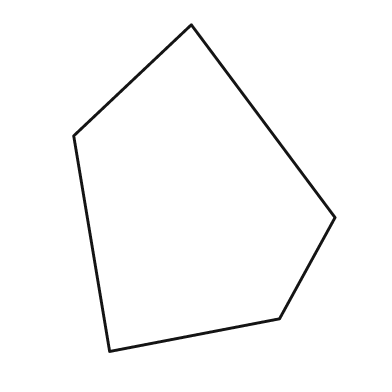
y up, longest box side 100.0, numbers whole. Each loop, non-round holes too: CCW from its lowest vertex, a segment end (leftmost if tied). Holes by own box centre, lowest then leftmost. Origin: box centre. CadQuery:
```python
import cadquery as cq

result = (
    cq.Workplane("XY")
    .moveTo(-29.0, -50.0)
    .lineTo(23.0, -40.0)
    .lineTo(40.0, -9.0)
    .lineTo(-4.0, 50.0)
    .lineTo(-40.0, 16.0)
    .close()
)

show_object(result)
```